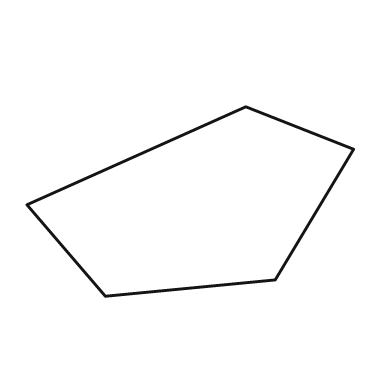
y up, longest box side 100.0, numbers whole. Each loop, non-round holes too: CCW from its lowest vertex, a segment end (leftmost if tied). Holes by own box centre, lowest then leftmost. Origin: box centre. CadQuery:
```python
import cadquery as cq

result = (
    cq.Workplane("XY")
    .moveTo(-26.0, -29.0)
    .lineTo(26.0, -24.0)
    .lineTo(50.0, 16.0)
    .lineTo(17.0, 29.0)
    .lineTo(-50.0, -1.0)
    .close()
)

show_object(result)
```